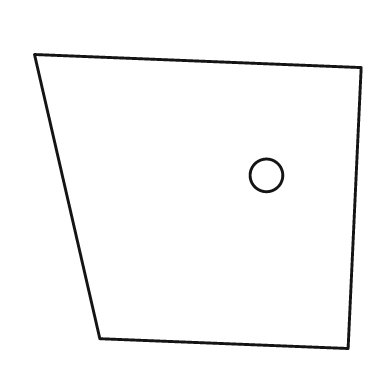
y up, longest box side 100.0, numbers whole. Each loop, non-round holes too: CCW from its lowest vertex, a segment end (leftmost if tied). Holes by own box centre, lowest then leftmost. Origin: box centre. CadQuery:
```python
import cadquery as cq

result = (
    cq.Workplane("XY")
    .moveTo(46.0, -45.0)
    .lineTo(50.0, 41.0)
    .lineTo(-50.0, 45.0)
    .lineTo(-30.0, -42.0)
    .close()
    .moveTo(21.0, 8.0)
    .circle(5.0)
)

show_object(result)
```